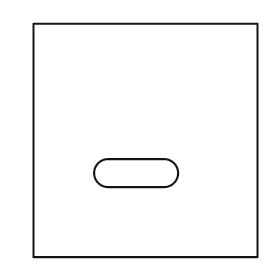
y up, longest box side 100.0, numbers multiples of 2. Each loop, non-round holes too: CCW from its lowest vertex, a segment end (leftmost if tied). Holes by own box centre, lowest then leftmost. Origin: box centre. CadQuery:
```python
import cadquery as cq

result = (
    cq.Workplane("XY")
    .moveTo(-48.0, -50.0)
    .lineTo(48.0, -50.0)
    .lineTo(48.0, 50.0)
    .lineTo(-48.0, 50.0)
    .close()
    .moveTo(-16.0, -20.0)
    .lineTo(8.0, -20.0)
    .threePointArc((14.0, -14.0), (8.0, -8.0))
    .lineTo(-16.0, -8.0)
    .threePointArc((-22.0, -14.0), (-16.0, -20.0))
    .close()
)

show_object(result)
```